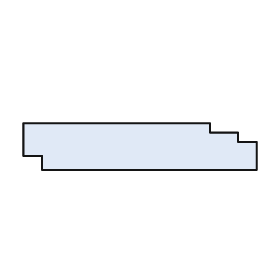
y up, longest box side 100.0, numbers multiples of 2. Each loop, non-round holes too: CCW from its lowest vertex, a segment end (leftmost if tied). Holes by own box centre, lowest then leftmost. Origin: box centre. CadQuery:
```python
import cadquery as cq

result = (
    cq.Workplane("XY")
    .moveTo(-42.0, -10.0)
    .lineTo(50.0, -10.0)
    .lineTo(50.0, 2.0)
    .lineTo(42.0, 2.0)
    .lineTo(42.0, 6.0)
    .lineTo(30.0, 6.0)
    .lineTo(30.0, 10.0)
    .lineTo(-50.0, 10.0)
    .lineTo(-50.0, -4.0)
    .lineTo(-42.0, -4.0)
    .close()
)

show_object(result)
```